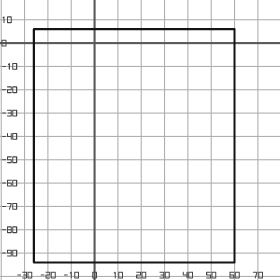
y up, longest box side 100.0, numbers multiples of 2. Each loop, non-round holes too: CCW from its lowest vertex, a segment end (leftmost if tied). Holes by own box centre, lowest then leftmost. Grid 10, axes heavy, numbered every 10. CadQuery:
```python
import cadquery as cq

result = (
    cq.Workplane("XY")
    .moveTo(-26.0, -94.0)
    .lineTo(60.0, -94.0)
    .lineTo(60.0, 6.0)
    .lineTo(-26.0, 6.0)
    .close()
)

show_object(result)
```